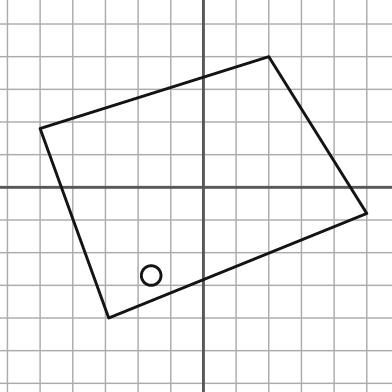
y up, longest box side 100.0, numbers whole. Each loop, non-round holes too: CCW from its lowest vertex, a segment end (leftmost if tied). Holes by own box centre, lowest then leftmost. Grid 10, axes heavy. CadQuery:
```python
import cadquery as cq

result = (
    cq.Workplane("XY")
    .moveTo(-29.0, -40.0)
    .lineTo(50.0, -8.0)
    .lineTo(20.0, 40.0)
    .lineTo(-50.0, 18.0)
    .close()
    .moveTo(-16.0, -27.0)
    .circle(3.0)
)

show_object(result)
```